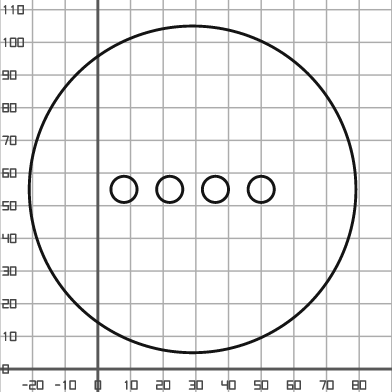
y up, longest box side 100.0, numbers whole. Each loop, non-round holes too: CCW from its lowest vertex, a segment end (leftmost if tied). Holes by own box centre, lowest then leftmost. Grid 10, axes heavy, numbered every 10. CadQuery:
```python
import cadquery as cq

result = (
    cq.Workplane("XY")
    .moveTo(29.0, 55.0)
    .circle(50.0)
    .moveTo(8.0, 55.0)
    .circle(4.0)
    .moveTo(22.0, 55.0)
    .circle(4.0)
    .moveTo(36.0, 55.0)
    .circle(4.0)
    .moveTo(50.0, 55.0)
    .circle(4.0)
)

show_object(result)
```